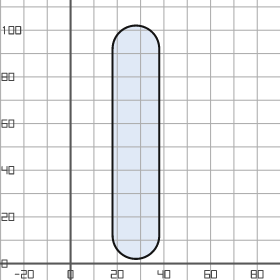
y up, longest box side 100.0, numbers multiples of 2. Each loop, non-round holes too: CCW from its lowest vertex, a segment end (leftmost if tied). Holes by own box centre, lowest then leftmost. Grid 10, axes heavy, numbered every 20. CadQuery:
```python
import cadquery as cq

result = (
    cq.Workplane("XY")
    .moveTo(18.0, 12.0)
    .threePointArc((28.0, 2.0), (38.0, 12.0))
    .lineTo(38.0, 92.0)
    .threePointArc((28.0, 102.0), (18.0, 92.0))
    .close()
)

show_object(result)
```